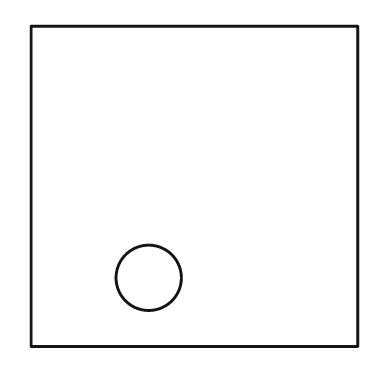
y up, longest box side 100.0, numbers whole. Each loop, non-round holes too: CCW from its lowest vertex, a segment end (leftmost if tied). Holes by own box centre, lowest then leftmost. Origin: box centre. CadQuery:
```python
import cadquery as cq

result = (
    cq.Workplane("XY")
    .moveTo(-50.0, -49.0)
    .lineTo(50.0, -49.0)
    .lineTo(50.0, 49.0)
    .lineTo(-50.0, 49.0)
    .close()
    .moveTo(-14.0, -28.0)
    .circle(10.0)
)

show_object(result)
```